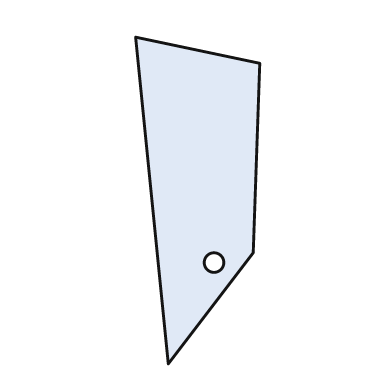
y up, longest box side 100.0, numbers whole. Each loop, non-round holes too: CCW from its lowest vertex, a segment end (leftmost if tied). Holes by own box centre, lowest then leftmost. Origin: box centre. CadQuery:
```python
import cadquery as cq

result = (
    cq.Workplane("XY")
    .moveTo(-9.0, -50.0)
    .lineTo(17.0, -16.0)
    .lineTo(19.0, 42.0)
    .lineTo(-19.0, 50.0)
    .close()
    .moveTo(5.0, -19.0)
    .circle(3.0)
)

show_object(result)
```